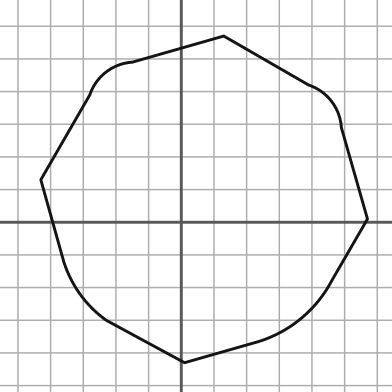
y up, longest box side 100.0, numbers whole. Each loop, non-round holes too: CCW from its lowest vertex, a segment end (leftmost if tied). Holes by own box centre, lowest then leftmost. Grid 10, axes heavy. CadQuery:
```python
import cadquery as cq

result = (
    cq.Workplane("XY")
    .moveTo(1.0, -43.0)
    .lineTo(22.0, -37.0)
    .threePointArc((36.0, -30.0), (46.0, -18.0))
    .lineTo(57.0, 1.0)
    .lineTo(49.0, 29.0)
    .threePointArc((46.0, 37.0), (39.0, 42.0))
    .lineTo(13.0, 57.0)
    .lineTo(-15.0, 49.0)
    .threePointArc((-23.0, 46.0), (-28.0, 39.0))
    .lineTo(-43.0, 13.0)
    .lineTo(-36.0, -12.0)
    .threePointArc((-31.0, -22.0), (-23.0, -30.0))
    .close()
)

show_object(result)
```